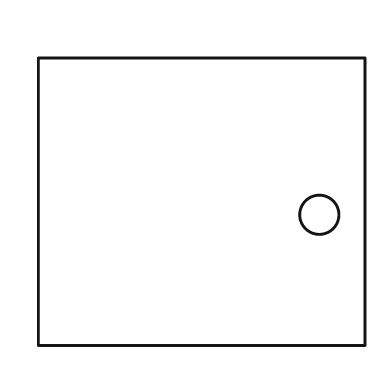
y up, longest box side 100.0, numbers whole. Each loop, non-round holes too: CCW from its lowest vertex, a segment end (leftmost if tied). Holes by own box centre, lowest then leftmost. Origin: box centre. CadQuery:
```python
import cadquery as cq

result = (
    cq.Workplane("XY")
    .moveTo(-50.0, -44.0)
    .lineTo(50.0, -44.0)
    .lineTo(50.0, 44.0)
    .lineTo(-50.0, 44.0)
    .close()
    .moveTo(36.0, -4.0)
    .circle(6.0)
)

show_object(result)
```